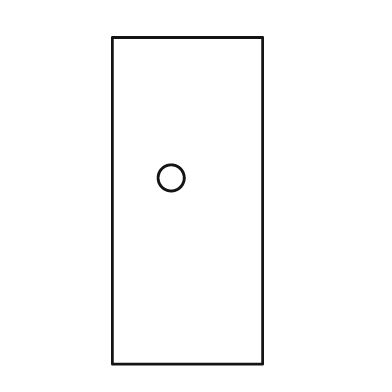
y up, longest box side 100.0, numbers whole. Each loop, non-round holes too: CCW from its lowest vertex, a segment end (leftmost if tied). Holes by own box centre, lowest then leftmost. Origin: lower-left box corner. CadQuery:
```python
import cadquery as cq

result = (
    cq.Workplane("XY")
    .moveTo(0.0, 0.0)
    .lineTo(46.0, 0.0)
    .lineTo(46.0, 100.0)
    .lineTo(0.0, 100.0)
    .close()
    .moveTo(18.0, 57.0)
    .circle(4.0)
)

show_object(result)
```